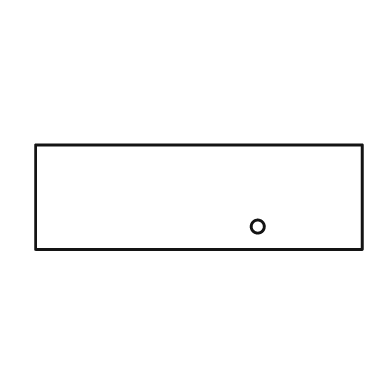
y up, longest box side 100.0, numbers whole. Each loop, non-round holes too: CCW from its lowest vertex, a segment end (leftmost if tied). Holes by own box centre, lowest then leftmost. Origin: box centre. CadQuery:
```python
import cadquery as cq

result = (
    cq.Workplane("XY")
    .moveTo(-50.0, -16.0)
    .lineTo(50.0, -16.0)
    .lineTo(50.0, 16.0)
    .lineTo(-50.0, 16.0)
    .close()
    .moveTo(18.0, -9.0)
    .circle(2.0)
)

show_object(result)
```